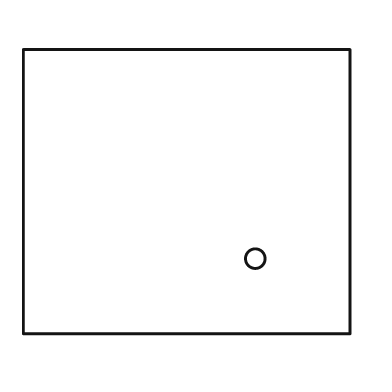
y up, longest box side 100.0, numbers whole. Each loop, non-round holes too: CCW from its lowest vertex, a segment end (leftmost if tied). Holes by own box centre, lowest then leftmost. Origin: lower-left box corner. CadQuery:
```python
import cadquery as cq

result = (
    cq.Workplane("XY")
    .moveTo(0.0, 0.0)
    .lineTo(100.0, 0.0)
    .lineTo(100.0, 87.0)
    .lineTo(0.0, 87.0)
    .close()
    .moveTo(71.0, 23.0)
    .circle(3.0)
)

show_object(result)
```